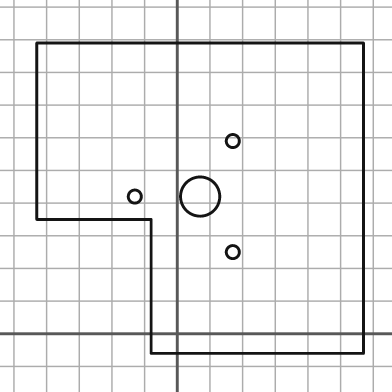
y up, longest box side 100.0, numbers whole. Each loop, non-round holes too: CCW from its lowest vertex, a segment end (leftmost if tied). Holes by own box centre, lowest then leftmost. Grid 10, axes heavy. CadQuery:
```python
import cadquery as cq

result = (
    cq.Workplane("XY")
    .moveTo(-8.0, -6.0)
    .lineTo(57.0, -6.0)
    .lineTo(57.0, 89.0)
    .lineTo(-43.0, 89.0)
    .lineTo(-43.0, 35.0)
    .lineTo(-8.0, 35.0)
    .close()
    .moveTo(17.0, 25.0)
    .circle(2.0)
    .moveTo(-13.0, 42.0)
    .circle(2.0)
    .moveTo(7.0, 42.0)
    .circle(6.0)
    .moveTo(17.0, 59.0)
    .circle(2.0)
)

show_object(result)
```